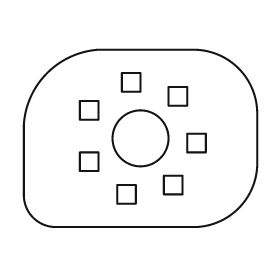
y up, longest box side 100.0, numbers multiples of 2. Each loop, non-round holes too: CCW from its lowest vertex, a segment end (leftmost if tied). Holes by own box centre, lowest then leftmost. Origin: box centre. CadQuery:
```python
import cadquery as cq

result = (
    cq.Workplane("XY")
    .moveTo(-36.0, -38.0)
    .lineTo(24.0, -38.0)
    .threePointArc((42.0, -30.0), (50.0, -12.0))
    .lineTo(50.0, 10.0)
    .threePointArc((42.0, 30.0), (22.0, 38.0))
    .lineTo(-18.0, 38.0)
    .threePointArc((-40.0, 28.0), (-50.0, 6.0))
    .lineTo(-50.0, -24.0)
    .threePointArc((-46.0, -34.0), (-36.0, -38.0))
    .close()
    .moveTo(-10.0, -28.0)
    .lineTo(-2.0, -28.0)
    .lineTo(-2.0, -20.0)
    .lineTo(-10.0, -20.0)
    .close()
    .moveTo(10.0, -24.0)
    .lineTo(18.0, -24.0)
    .lineTo(18.0, -16.0)
    .lineTo(10.0, -16.0)
    .close()
    .moveTo(-26.0, -14.0)
    .lineTo(-18.0, -14.0)
    .lineTo(-18.0, -6.0)
    .lineTo(-26.0, -6.0)
    .close()
    .moveTo(20.0, -6.0)
    .lineTo(28.0, -6.0)
    .lineTo(28.0, 2.0)
    .lineTo(20.0, 2.0)
    .close()
    .moveTo(0.0, 0.0)
    .circle(12.0)
    .moveTo(-26.0, 8.0)
    .lineTo(-18.0, 8.0)
    .lineTo(-18.0, 16.0)
    .lineTo(-26.0, 16.0)
    .close()
    .moveTo(12.0, 14.0)
    .lineTo(20.0, 14.0)
    .lineTo(20.0, 22.0)
    .lineTo(12.0, 22.0)
    .close()
    .moveTo(-8.0, 20.0)
    .lineTo(0.0, 20.0)
    .lineTo(0.0, 28.0)
    .lineTo(-8.0, 28.0)
    .close()
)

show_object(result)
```